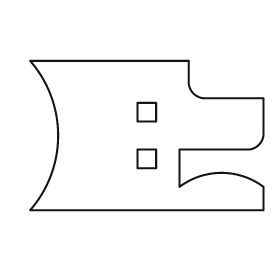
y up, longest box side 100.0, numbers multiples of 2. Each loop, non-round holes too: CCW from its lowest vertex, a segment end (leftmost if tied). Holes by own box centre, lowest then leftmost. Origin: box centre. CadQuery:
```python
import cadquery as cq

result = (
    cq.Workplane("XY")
    .moveTo(-50.0, -32.0)
    .lineTo(50.0, -32.0)
    .lineTo(50.0, -22.0)
    .threePointArc((32.0, -16.0), (14.0, -22.0))
    .lineTo(14.0, -6.0)
    .lineTo(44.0, -6.0)
    .threePointArc((48.0, -4.0), (50.0, 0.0))
    .lineTo(50.0, 16.0)
    .lineTo(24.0, 16.0)
    .threePointArc((20.0, 18.0), (18.0, 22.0))
    .lineTo(18.0, 32.0)
    .lineTo(-50.0, 32.0)
    .threePointArc((-38.0, 0.0), (-50.0, -32.0))
    .close()
    .moveTo(-4.0, -14.0)
    .lineTo(4.0, -14.0)
    .lineTo(4.0, -6.0)
    .lineTo(-4.0, -6.0)
    .close()
    .moveTo(-4.0, 6.0)
    .lineTo(4.0, 6.0)
    .lineTo(4.0, 14.0)
    .lineTo(-4.0, 14.0)
    .close()
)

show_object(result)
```